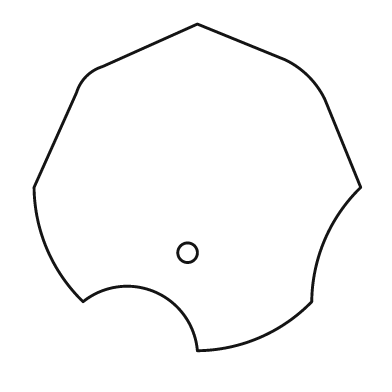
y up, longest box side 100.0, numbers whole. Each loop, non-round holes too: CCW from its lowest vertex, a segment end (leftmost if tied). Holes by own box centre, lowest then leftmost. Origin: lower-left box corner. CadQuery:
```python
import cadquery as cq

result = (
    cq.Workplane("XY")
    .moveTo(50.0, 0.0)
    .threePointArc((69.0, 4.0), (85.0, 15.0))
    .threePointArc((89.0, 34.0), (100.0, 50.0))
    .lineTo(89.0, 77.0)
    .threePointArc((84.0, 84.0), (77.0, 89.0))
    .lineTo(50.0, 100.0)
    .lineTo(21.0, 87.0)
    .threePointArc((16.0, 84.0), (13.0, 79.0))
    .lineTo(0.0, 50.0)
    .threePointArc((4.0, 31.0), (15.0, 15.0))
    .threePointArc((37.0, 18.0), (50.0, 0.0))
    .close()
    .moveTo(47.0, 30.0)
    .circle(3.0)
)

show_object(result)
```